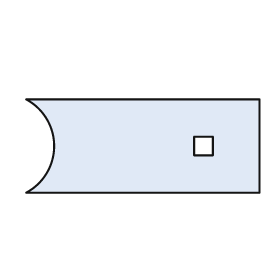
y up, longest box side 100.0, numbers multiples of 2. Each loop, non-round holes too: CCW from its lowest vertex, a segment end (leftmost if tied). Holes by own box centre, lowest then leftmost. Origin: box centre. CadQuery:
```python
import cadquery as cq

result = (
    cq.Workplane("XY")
    .moveTo(-50.0, -20.0)
    .lineTo(50.0, -20.0)
    .lineTo(50.0, 20.0)
    .lineTo(-50.0, 20.0)
    .threePointArc((-38.0, 0.0), (-50.0, -20.0))
    .close()
    .moveTo(22.0, -4.0)
    .lineTo(30.0, -4.0)
    .lineTo(30.0, 4.0)
    .lineTo(22.0, 4.0)
    .close()
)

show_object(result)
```